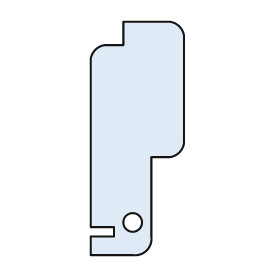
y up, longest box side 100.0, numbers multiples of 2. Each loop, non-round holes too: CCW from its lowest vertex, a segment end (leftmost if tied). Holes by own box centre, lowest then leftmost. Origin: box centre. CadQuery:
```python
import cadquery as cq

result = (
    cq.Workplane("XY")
    .moveTo(-20.0, -50.0)
    .lineTo(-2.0, -50.0)
    .threePointArc((4.0, -48.0), (6.0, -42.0))
    .lineTo(6.0, -8.0)
    .lineTo(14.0, -8.0)
    .threePointArc((18.0, -6.0), (20.0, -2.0))
    .lineTo(20.0, 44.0)
    .threePointArc((18.0, 48.0), (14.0, 50.0))
    .lineTo(-6.0, 50.0)
    .lineTo(-6.0, 40.0)
    .lineTo(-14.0, 40.0)
    .threePointArc((-18.0, 38.0), (-20.0, 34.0))
    .lineTo(-20.0, -38.0)
    .lineTo(-10.0, -38.0)
    .lineTo(-10.0, -42.0)
    .lineTo(-20.0, -42.0)
    .close()
    .moveTo(-2.0, -36.0)
    .circle(4.0)
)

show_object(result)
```